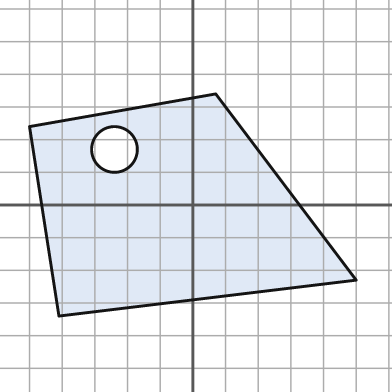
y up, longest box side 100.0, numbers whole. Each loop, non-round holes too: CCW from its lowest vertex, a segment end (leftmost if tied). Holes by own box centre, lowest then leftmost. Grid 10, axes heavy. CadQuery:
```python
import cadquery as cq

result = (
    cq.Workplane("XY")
    .moveTo(-41.0, -34.0)
    .lineTo(50.0, -23.0)
    .lineTo(7.0, 34.0)
    .lineTo(-50.0, 24.0)
    .close()
    .moveTo(-24.0, 17.0)
    .circle(7.0)
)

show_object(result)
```